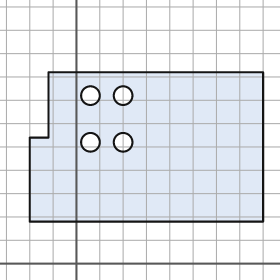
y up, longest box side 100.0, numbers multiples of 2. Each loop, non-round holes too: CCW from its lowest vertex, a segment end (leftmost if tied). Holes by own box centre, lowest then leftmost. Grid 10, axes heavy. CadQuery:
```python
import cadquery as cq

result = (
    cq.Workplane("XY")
    .moveTo(-20.0, 18.0)
    .lineTo(80.0, 18.0)
    .lineTo(80.0, 82.0)
    .lineTo(-12.0, 82.0)
    .lineTo(-12.0, 54.0)
    .lineTo(-20.0, 54.0)
    .close()
    .moveTo(6.0, 52.0)
    .circle(4.0)
    .moveTo(20.0, 52.0)
    .circle(4.0)
    .moveTo(6.0, 72.0)
    .circle(4.0)
    .moveTo(20.0, 72.0)
    .circle(4.0)
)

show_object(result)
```